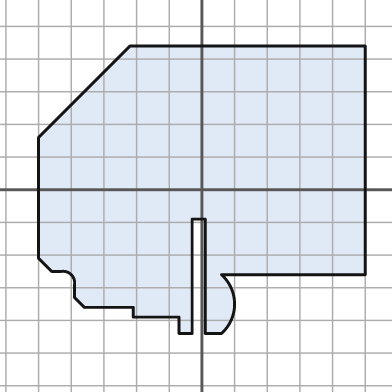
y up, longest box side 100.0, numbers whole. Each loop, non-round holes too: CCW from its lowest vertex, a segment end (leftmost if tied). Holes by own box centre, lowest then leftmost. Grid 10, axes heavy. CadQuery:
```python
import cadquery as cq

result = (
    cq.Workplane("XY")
    .moveTo(-7.0, -44.0)
    .lineTo(-3.0, -44.0)
    .lineTo(-3.0, -9.0)
    .lineTo(1.0, -9.0)
    .lineTo(1.0, -44.0)
    .lineTo(6.0, -44.0)
    .threePointArc((10.0, -35.0), (6.0, -26.0))
    .lineTo(50.0, -26.0)
    .lineTo(50.0, 44.0)
    .lineTo(-22.0, 44.0)
    .lineTo(-50.0, 16.0)
    .lineTo(-50.0, -21.0)
    .lineTo(-46.0, -25.0)
    .lineTo(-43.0, -25.0)
    .threePointArc((-40.0, -26.0), (-39.0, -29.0))
    .lineTo(-39.0, -33.0)
    .lineTo(-36.0, -36.0)
    .lineTo(-21.0, -36.0)
    .lineTo(-21.0, -39.0)
    .lineTo(-7.0, -39.0)
    .close()
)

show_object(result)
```